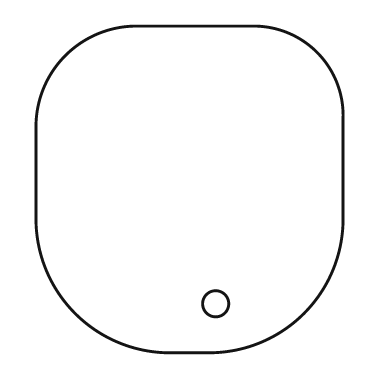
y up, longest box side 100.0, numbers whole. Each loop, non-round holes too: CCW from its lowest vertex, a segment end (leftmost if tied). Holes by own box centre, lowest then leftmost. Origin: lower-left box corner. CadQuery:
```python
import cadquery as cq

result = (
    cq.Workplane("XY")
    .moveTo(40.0, 0.0)
    .lineTo(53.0, 0.0)
    .threePointArc((82.0, 12.0), (94.0, 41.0))
    .lineTo(94.0, 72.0)
    .threePointArc((86.0, 92.0), (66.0, 100.0))
    .lineTo(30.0, 100.0)
    .threePointArc((9.0, 91.0), (0.0, 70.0))
    .lineTo(0.0, 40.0)
    .threePointArc((12.0, 12.0), (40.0, 0.0))
    .close()
    .moveTo(55.0, 15.0)
    .circle(4.0)
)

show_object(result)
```